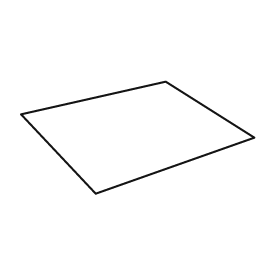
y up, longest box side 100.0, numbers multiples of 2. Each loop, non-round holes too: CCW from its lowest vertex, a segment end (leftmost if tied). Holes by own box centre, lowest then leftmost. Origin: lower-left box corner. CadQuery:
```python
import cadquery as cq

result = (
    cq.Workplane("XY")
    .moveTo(32.0, 0.0)
    .lineTo(100.0, 24.0)
    .lineTo(62.0, 48.0)
    .lineTo(0.0, 34.0)
    .close()
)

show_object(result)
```